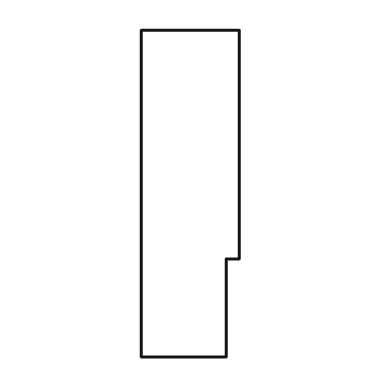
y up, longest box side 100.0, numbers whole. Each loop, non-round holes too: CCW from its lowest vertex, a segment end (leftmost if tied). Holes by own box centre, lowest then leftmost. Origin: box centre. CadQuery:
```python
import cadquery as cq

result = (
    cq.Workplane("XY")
    .moveTo(-15.0, -50.0)
    .lineTo(11.0, -50.0)
    .lineTo(11.0, -20.0)
    .lineTo(15.0, -20.0)
    .lineTo(15.0, 50.0)
    .lineTo(-15.0, 50.0)
    .close()
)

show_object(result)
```